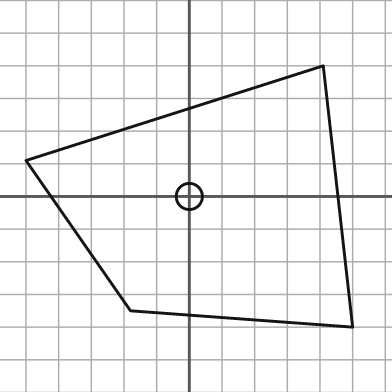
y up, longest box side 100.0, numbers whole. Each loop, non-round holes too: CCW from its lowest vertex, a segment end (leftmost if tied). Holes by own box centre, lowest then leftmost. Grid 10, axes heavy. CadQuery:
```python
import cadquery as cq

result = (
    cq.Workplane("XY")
    .moveTo(50.0, -40.0)
    .lineTo(41.0, 40.0)
    .lineTo(-50.0, 11.0)
    .lineTo(-18.0, -35.0)
    .close()
    .moveTo(0.0, 0.0)
    .circle(4.0)
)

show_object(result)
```